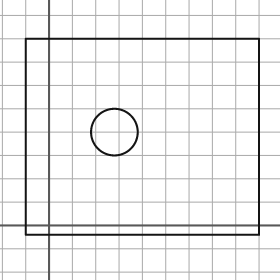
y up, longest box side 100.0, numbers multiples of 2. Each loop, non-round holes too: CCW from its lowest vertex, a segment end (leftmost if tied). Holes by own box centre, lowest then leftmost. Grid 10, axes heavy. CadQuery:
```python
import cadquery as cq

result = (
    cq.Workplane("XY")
    .moveTo(-10.0, -4.0)
    .lineTo(90.0, -4.0)
    .lineTo(90.0, 80.0)
    .lineTo(-10.0, 80.0)
    .close()
    .moveTo(28.0, 40.0)
    .circle(10.0)
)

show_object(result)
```